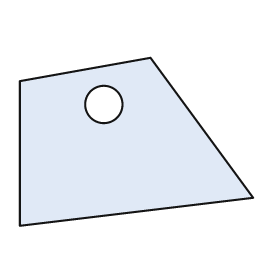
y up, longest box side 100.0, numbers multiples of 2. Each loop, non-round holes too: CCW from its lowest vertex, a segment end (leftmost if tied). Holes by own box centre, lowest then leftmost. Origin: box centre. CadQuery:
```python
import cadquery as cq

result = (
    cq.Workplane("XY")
    .moveTo(-50.0, -36.0)
    .lineTo(50.0, -24.0)
    .lineTo(6.0, 36.0)
    .lineTo(-50.0, 26.0)
    .close()
    .moveTo(-14.0, 16.0)
    .circle(8.0)
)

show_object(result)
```